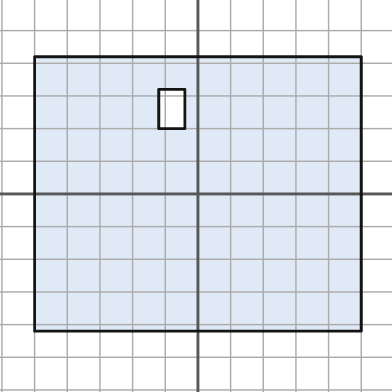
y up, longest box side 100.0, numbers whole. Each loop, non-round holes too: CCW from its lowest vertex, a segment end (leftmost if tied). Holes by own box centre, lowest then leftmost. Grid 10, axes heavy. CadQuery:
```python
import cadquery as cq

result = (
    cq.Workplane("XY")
    .moveTo(-50.0, -42.0)
    .lineTo(50.0, -42.0)
    .lineTo(50.0, 42.0)
    .lineTo(-50.0, 42.0)
    .close()
    .moveTo(-12.0, 20.0)
    .lineTo(-4.0, 20.0)
    .lineTo(-4.0, 32.0)
    .lineTo(-12.0, 32.0)
    .close()
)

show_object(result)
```